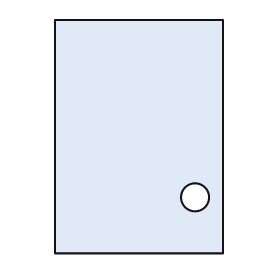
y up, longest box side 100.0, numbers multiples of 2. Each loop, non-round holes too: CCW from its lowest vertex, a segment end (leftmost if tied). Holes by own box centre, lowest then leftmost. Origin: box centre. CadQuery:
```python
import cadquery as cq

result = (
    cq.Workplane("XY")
    .moveTo(-36.0, -50.0)
    .lineTo(36.0, -50.0)
    .lineTo(36.0, 50.0)
    .lineTo(-36.0, 50.0)
    .close()
    .moveTo(24.0, -26.0)
    .circle(6.0)
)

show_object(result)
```